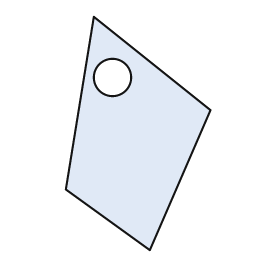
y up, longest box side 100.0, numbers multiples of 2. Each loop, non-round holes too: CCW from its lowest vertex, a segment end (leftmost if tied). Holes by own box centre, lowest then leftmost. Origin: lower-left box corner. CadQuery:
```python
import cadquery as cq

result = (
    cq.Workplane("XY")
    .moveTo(36.0, 0.0)
    .lineTo(62.0, 60.0)
    .lineTo(12.0, 100.0)
    .lineTo(0.0, 26.0)
    .close()
    .moveTo(20.0, 74.0)
    .circle(8.0)
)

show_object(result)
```